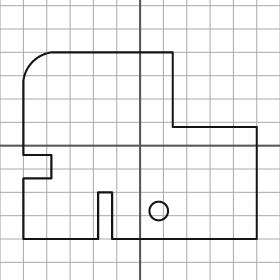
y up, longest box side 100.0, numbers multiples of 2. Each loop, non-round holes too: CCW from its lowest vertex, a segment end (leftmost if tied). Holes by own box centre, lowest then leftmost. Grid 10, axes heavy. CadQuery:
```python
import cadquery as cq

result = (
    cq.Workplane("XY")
    .moveTo(-50.0, -40.0)
    .lineTo(-18.0, -40.0)
    .lineTo(-18.0, -20.0)
    .lineTo(-12.0, -20.0)
    .lineTo(-12.0, -40.0)
    .lineTo(50.0, -40.0)
    .lineTo(50.0, 8.0)
    .lineTo(14.0, 8.0)
    .lineTo(14.0, 40.0)
    .lineTo(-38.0, 40.0)
    .threePointArc((-46.0, 36.0), (-50.0, 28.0))
    .lineTo(-50.0, -4.0)
    .lineTo(-38.0, -4.0)
    .lineTo(-38.0, -14.0)
    .lineTo(-50.0, -14.0)
    .close()
    .moveTo(8.0, -28.0)
    .circle(4.0)
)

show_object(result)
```